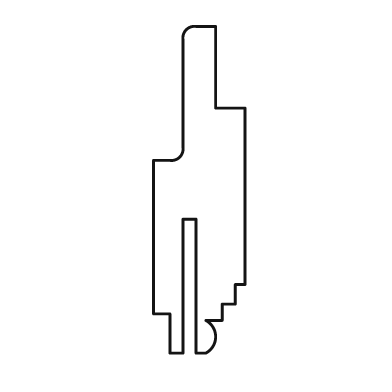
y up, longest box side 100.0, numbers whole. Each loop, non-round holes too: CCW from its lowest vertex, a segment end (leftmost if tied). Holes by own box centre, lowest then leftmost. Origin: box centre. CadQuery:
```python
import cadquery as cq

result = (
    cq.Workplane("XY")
    .moveTo(-9.0, -50.0)
    .lineTo(-5.0, -50.0)
    .lineTo(-5.0, -9.0)
    .lineTo(-1.0, -9.0)
    .lineTo(-1.0, -50.0)
    .lineTo(2.0, -50.0)
    .threePointArc((5.0, -45.0), (2.0, -40.0))
    .lineTo(7.0, -40.0)
    .lineTo(7.0, -35.0)
    .lineTo(11.0, -35.0)
    .lineTo(11.0, -29.0)
    .lineTo(14.0, -29.0)
    .lineTo(14.0, 25.0)
    .lineTo(5.0, 25.0)
    .lineTo(5.0, 50.0)
    .lineTo(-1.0, 50.0)
    .threePointArc((-4.0, 49.0), (-5.0, 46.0))
    .lineTo(-5.0, 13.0)
    .threePointArc((-6.0, 10.0), (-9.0, 9.0))
    .lineTo(-14.0, 9.0)
    .lineTo(-14.0, -38.0)
    .lineTo(-9.0, -38.0)
    .close()
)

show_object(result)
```